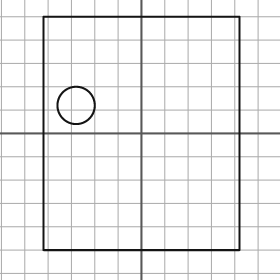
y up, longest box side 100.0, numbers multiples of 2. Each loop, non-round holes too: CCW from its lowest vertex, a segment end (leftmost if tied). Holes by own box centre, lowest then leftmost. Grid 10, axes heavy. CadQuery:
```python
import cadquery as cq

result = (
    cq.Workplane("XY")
    .moveTo(-42.0, -50.0)
    .lineTo(42.0, -50.0)
    .lineTo(42.0, 50.0)
    .lineTo(-42.0, 50.0)
    .close()
    .moveTo(-28.0, 12.0)
    .circle(8.0)
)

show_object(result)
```